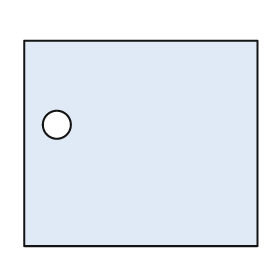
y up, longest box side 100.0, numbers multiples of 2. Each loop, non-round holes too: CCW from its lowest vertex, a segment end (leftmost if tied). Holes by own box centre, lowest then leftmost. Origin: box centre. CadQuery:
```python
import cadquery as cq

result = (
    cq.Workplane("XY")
    .moveTo(-50.0, -44.0)
    .lineTo(50.0, -44.0)
    .lineTo(50.0, 44.0)
    .lineTo(-50.0, 44.0)
    .close()
    .moveTo(-36.0, 8.0)
    .circle(6.0)
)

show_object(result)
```